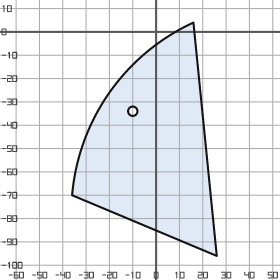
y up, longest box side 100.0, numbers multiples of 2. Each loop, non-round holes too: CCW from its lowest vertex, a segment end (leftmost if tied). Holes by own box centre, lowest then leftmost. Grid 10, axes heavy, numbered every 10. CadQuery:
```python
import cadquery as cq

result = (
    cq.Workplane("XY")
    .moveTo(26.0, -96.0)
    .lineTo(16.0, 4.0)
    .threePointArc((-20.0, -26.0), (-36.0, -70.0))
    .close()
    .moveTo(-10.0, -34.0)
    .circle(2.0)
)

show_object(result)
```